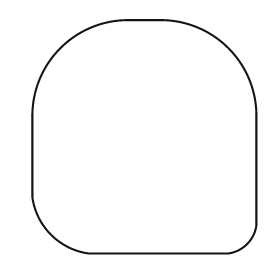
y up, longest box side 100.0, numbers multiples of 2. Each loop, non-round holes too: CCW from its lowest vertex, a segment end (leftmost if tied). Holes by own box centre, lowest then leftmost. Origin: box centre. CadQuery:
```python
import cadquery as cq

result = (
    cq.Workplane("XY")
    .moveTo(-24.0, -50.0)
    .lineTo(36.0, -50.0)
    .threePointArc((44.0, -46.0), (48.0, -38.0))
    .lineTo(48.0, 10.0)
    .threePointArc((36.0, 38.0), (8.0, 50.0))
    .lineTo(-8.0, 50.0)
    .threePointArc((-36.0, 38.0), (-48.0, 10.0))
    .lineTo(-48.0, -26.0)
    .threePointArc((-40.0, -42.0), (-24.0, -50.0))
    .close()
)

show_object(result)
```